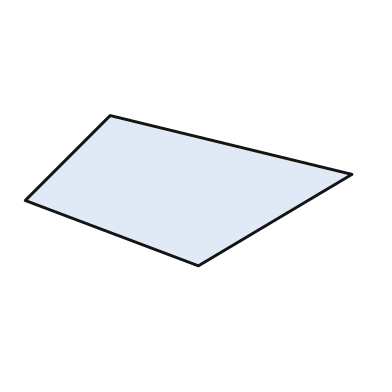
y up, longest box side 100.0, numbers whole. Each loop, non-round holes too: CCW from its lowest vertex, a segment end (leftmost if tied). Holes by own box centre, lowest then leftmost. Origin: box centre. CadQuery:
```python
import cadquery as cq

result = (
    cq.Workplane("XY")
    .moveTo(3.0, -23.0)
    .lineTo(50.0, 5.0)
    .lineTo(-24.0, 23.0)
    .lineTo(-50.0, -3.0)
    .close()
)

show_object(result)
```